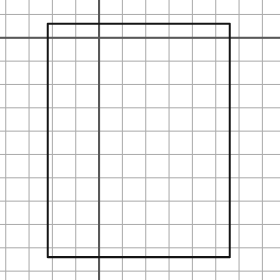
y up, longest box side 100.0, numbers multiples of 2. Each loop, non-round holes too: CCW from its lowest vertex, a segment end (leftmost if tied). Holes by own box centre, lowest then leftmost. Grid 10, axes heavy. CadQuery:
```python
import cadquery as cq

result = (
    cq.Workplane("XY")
    .moveTo(-22.0, -94.0)
    .lineTo(56.0, -94.0)
    .lineTo(56.0, 6.0)
    .lineTo(-22.0, 6.0)
    .close()
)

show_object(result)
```